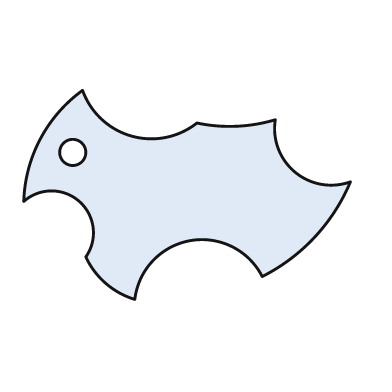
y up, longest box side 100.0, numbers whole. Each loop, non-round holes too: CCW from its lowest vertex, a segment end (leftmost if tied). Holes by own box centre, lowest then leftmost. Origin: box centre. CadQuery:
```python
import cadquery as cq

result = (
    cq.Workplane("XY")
    .moveTo(-16.0, -32.0)
    .threePointArc((1.0, -14.0), (23.0, -25.0))
    .threePointArc((39.0, -13.0), (50.0, 4.0))
    .threePointArc((33.0, 7.0), (27.0, 23.0))
    .threePointArc((15.0, 21.0), (3.0, 22.0))
    .threePointArc((-17.0, 18.0), (-32.0, 32.0))
    .threePointArc((-45.0, 17.0), (-50.0, -2.0))
    .threePointArc((-33.0, -2.0), (-31.0, -19.0))
    .threePointArc((-25.0, -27.0), (-16.0, -32.0))
    .close()
    .moveTo(-35.0, 13.0)
    .circle(4.0)
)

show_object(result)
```